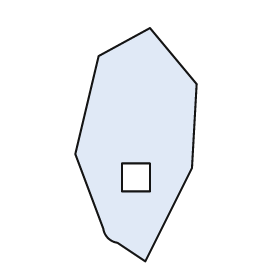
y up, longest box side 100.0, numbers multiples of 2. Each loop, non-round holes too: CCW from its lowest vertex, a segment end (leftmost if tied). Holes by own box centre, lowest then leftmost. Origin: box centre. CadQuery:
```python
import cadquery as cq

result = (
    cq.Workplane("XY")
    .moveTo(4.0, -50.0)
    .lineTo(24.0, -10.0)
    .lineTo(26.0, 26.0)
    .lineTo(6.0, 50.0)
    .lineTo(-16.0, 38.0)
    .lineTo(-26.0, -4.0)
    .lineTo(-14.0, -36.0)
    .threePointArc((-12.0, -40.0), (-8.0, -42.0))
    .close()
    .moveTo(-6.0, -20.0)
    .lineTo(6.0, -20.0)
    .lineTo(6.0, -8.0)
    .lineTo(-6.0, -8.0)
    .close()
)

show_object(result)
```